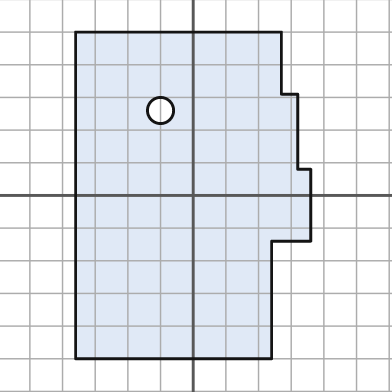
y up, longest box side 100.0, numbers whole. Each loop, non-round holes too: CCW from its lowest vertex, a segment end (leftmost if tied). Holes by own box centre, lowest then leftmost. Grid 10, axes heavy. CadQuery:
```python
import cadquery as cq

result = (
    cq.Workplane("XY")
    .moveTo(-36.0, -50.0)
    .lineTo(24.0, -50.0)
    .lineTo(24.0, -14.0)
    .lineTo(36.0, -14.0)
    .lineTo(36.0, 8.0)
    .lineTo(32.0, 8.0)
    .lineTo(32.0, 31.0)
    .lineTo(27.0, 31.0)
    .lineTo(27.0, 50.0)
    .lineTo(-36.0, 50.0)
    .close()
    .moveTo(-10.0, 26.0)
    .circle(4.0)
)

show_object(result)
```